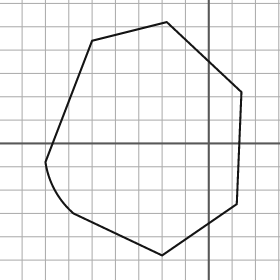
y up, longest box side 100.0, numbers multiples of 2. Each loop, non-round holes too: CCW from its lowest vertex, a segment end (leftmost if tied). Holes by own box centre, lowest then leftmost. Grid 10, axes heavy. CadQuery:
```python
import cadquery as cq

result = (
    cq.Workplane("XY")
    .moveTo(-20.0, -48.0)
    .lineTo(12.0, -26.0)
    .lineTo(14.0, 22.0)
    .lineTo(-18.0, 52.0)
    .lineTo(-50.0, 44.0)
    .lineTo(-70.0, -8.0)
    .threePointArc((-66.0, -20.0), (-58.0, -30.0))
    .close()
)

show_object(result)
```